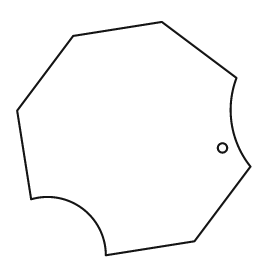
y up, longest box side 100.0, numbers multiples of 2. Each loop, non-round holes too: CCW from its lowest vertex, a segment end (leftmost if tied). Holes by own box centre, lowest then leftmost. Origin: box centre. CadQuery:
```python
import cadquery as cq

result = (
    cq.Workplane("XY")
    .moveTo(-12.0, -50.0)
    .lineTo(26.0, -44.0)
    .lineTo(50.0, -12.0)
    .threePointArc((42.0, 6.0), (44.0, 26.0))
    .lineTo(12.0, 50.0)
    .lineTo(-26.0, 44.0)
    .lineTo(-50.0, 12.0)
    .lineTo(-44.0, -26.0)
    .threePointArc((-22.0, -30.0), (-12.0, -50.0))
    .close()
    .moveTo(38.0, -4.0)
    .circle(2.0)
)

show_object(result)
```